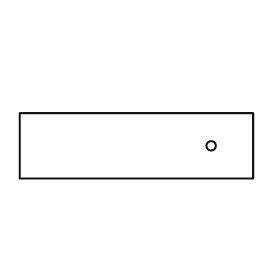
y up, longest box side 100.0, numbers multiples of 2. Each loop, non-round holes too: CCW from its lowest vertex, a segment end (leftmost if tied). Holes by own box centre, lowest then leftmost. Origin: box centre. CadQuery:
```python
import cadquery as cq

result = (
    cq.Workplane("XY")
    .moveTo(-50.0, -14.0)
    .lineTo(50.0, -14.0)
    .lineTo(50.0, 14.0)
    .lineTo(-50.0, 14.0)
    .close()
    .moveTo(32.0, 0.0)
    .circle(2.0)
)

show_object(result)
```